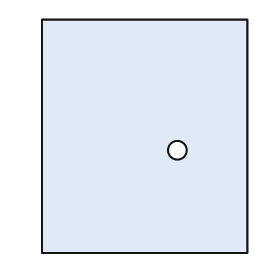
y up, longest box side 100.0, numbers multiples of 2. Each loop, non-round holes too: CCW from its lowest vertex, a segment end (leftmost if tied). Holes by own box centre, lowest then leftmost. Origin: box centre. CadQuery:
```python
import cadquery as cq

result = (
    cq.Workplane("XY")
    .moveTo(-44.0, -50.0)
    .lineTo(44.0, -50.0)
    .lineTo(44.0, 50.0)
    .lineTo(-44.0, 50.0)
    .close()
    .moveTo(14.0, -6.0)
    .circle(4.0)
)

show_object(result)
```